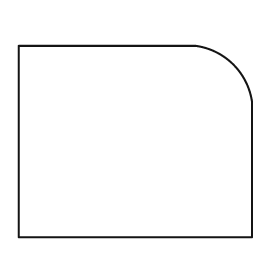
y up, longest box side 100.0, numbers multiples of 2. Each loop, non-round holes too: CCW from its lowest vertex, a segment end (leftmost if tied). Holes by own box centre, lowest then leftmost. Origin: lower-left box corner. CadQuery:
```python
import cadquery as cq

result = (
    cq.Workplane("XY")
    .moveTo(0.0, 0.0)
    .lineTo(100.0, 0.0)
    .lineTo(100.0, 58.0)
    .threePointArc((92.0, 74.0), (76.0, 82.0))
    .lineTo(0.0, 82.0)
    .close()
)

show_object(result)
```